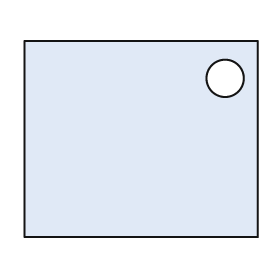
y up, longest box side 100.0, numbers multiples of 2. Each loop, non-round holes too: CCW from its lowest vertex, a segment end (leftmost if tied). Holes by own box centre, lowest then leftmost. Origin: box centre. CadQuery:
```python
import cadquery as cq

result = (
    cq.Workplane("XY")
    .moveTo(-50.0, -42.0)
    .lineTo(50.0, -42.0)
    .lineTo(50.0, 42.0)
    .lineTo(-50.0, 42.0)
    .close()
    .moveTo(36.0, 26.0)
    .circle(8.0)
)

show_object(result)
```